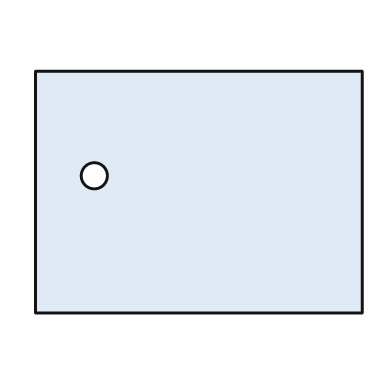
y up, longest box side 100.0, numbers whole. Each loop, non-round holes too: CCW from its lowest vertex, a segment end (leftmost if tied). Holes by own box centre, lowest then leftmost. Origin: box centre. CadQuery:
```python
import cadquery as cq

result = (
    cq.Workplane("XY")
    .moveTo(-50.0, -37.0)
    .lineTo(50.0, -37.0)
    .lineTo(50.0, 37.0)
    .lineTo(-50.0, 37.0)
    .close()
    .moveTo(-32.0, 5.0)
    .circle(4.0)
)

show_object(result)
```